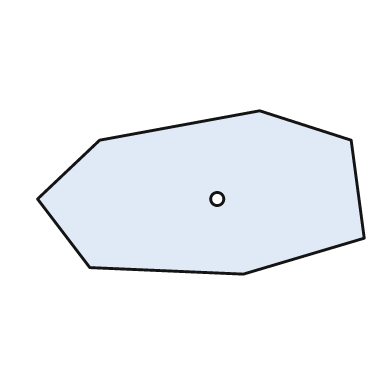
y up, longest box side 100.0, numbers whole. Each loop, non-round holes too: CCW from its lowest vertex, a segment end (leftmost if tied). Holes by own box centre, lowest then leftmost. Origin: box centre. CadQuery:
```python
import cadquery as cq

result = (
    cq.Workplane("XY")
    .moveTo(13.0, -25.0)
    .lineTo(50.0, -14.0)
    .lineTo(46.0, 16.0)
    .lineTo(18.0, 25.0)
    .lineTo(-31.0, 16.0)
    .lineTo(-50.0, -2.0)
    .lineTo(-34.0, -23.0)
    .close()
    .moveTo(5.0, -2.0)
    .circle(2.0)
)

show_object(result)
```